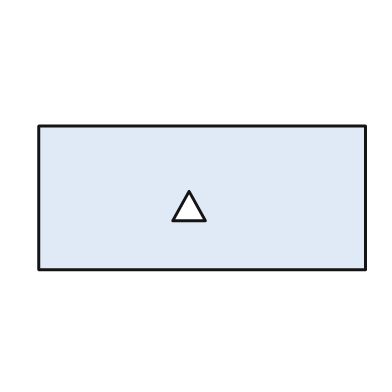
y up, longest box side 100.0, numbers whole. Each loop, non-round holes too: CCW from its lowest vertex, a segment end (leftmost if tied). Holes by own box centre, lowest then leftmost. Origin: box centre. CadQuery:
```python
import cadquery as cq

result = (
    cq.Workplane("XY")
    .moveTo(-50.0, -22.0)
    .lineTo(50.0, -22.0)
    .lineTo(50.0, 22.0)
    .lineTo(-50.0, 22.0)
    .close()
    .moveTo(-9.0, -7.0)
    .lineTo(1.0, -7.0)
    .lineTo(-4.0, 2.0)
    .close()
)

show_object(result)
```